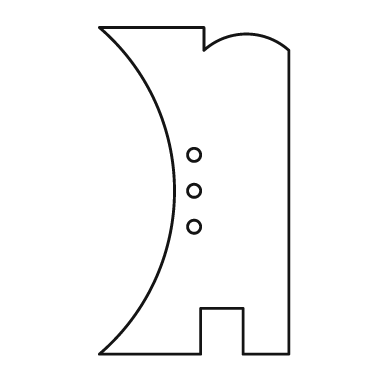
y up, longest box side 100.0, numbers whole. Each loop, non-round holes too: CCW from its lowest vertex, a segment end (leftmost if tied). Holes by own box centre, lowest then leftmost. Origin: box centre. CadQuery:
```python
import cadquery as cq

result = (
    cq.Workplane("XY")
    .moveTo(-29.0, -50.0)
    .lineTo(2.0, -50.0)
    .lineTo(2.0, -36.0)
    .lineTo(15.0, -36.0)
    .lineTo(15.0, -50.0)
    .lineTo(29.0, -50.0)
    .lineTo(29.0, 43.0)
    .threePointArc((16.0, 48.0), (3.0, 43.0))
    .lineTo(3.0, 50.0)
    .lineTo(-29.0, 50.0)
    .threePointArc((-6.0, 0.0), (-29.0, -50.0))
    .close()
    .moveTo(0.0, -11.0)
    .circle(2.0)
    .moveTo(0.0, 0.0)
    .circle(2.0)
    .moveTo(0.0, 11.0)
    .circle(2.0)
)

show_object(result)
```